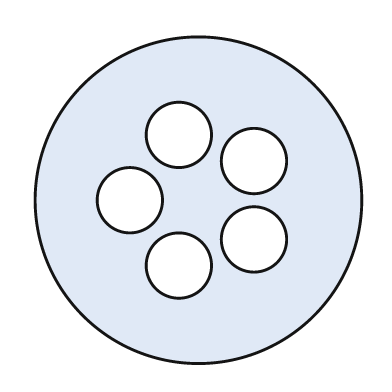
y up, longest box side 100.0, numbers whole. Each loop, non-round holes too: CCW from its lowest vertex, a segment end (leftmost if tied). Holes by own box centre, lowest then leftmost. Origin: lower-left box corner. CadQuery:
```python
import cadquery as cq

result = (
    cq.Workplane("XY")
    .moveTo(50.0, 50.0)
    .circle(50.0)
    .moveTo(44.0, 30.0)
    .circle(10.0)
    .moveTo(67.0, 38.0)
    .circle(10.0)
    .moveTo(29.0, 50.0)
    .circle(10.0)
    .moveTo(67.0, 62.0)
    .circle(10.0)
    .moveTo(44.0, 70.0)
    .circle(10.0)
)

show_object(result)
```